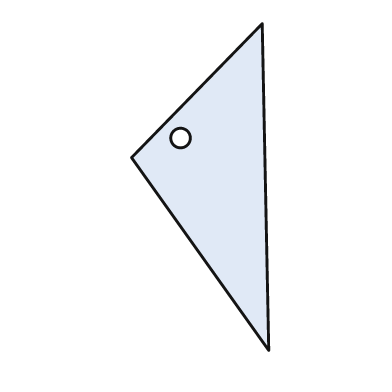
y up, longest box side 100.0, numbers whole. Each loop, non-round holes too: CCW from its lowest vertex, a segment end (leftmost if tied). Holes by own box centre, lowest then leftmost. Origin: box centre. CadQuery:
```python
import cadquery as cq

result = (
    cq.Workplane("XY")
    .moveTo(21.0, -50.0)
    .lineTo(19.0, 50.0)
    .lineTo(-21.0, 9.0)
    .close()
    .moveTo(-6.0, 15.0)
    .circle(3.0)
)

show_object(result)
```